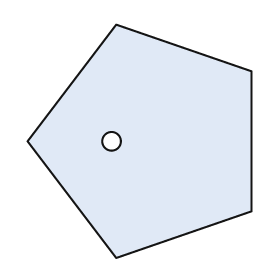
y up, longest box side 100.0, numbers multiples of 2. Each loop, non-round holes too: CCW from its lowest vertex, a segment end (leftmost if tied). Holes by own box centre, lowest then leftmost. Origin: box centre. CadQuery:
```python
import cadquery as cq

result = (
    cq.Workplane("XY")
    .moveTo(-10.0, -50.0)
    .lineTo(48.0, -30.0)
    .lineTo(48.0, 30.0)
    .lineTo(-10.0, 50.0)
    .lineTo(-48.0, 0.0)
    .close()
    .moveTo(-12.0, 0.0)
    .circle(4.0)
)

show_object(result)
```